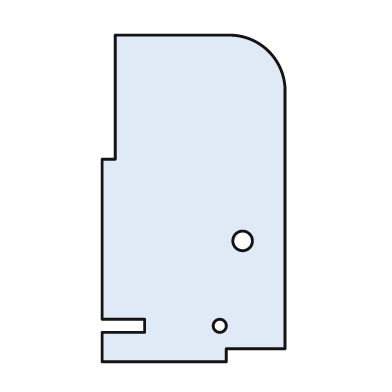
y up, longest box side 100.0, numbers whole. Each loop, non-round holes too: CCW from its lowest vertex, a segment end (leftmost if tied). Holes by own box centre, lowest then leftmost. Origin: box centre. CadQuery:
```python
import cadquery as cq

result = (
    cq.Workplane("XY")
    .moveTo(-28.0, -50.0)
    .lineTo(10.0, -50.0)
    .lineTo(10.0, -46.0)
    .lineTo(28.0, -46.0)
    .lineTo(28.0, 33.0)
    .threePointArc((23.0, 45.0), (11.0, 50.0))
    .lineTo(-24.0, 50.0)
    .lineTo(-24.0, 12.0)
    .lineTo(-28.0, 12.0)
    .lineTo(-28.0, -37.0)
    .lineTo(-15.0, -37.0)
    .lineTo(-15.0, -41.0)
    .lineTo(-28.0, -41.0)
    .close()
    .moveTo(8.0, -39.0)
    .circle(2.0)
    .moveTo(15.0, -13.0)
    .circle(3.0)
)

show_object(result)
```